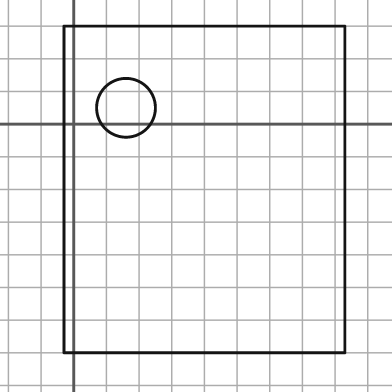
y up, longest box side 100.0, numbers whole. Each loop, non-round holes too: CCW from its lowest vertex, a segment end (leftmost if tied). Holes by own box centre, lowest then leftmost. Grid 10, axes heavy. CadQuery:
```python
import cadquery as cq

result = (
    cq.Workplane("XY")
    .moveTo(-3.0, -70.0)
    .lineTo(83.0, -70.0)
    .lineTo(83.0, 30.0)
    .lineTo(-3.0, 30.0)
    .close()
    .moveTo(16.0, 5.0)
    .circle(9.0)
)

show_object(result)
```